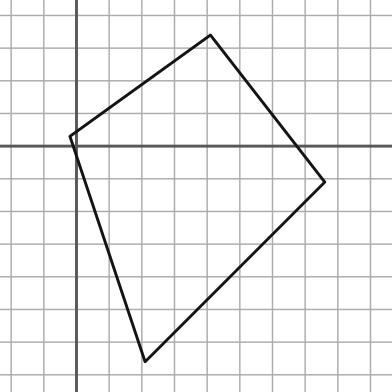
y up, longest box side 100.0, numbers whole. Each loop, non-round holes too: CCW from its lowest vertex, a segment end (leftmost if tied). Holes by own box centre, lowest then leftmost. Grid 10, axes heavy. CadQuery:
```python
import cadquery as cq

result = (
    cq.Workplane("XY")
    .moveTo(21.0, -66.0)
    .lineTo(76.0, -11.0)
    .lineTo(41.0, 34.0)
    .lineTo(-2.0, 3.0)
    .close()
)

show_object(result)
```